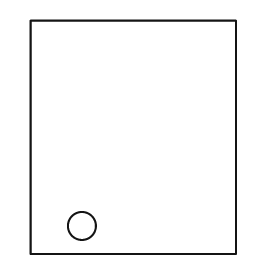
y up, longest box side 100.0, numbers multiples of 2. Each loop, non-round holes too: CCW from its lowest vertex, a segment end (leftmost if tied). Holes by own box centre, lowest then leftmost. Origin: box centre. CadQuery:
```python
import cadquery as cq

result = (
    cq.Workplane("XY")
    .moveTo(-44.0, -50.0)
    .lineTo(44.0, -50.0)
    .lineTo(44.0, 50.0)
    .lineTo(-44.0, 50.0)
    .close()
    .moveTo(-22.0, -38.0)
    .circle(6.0)
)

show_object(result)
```